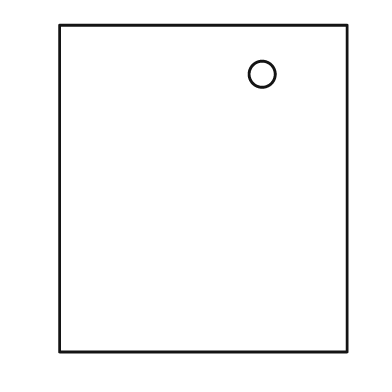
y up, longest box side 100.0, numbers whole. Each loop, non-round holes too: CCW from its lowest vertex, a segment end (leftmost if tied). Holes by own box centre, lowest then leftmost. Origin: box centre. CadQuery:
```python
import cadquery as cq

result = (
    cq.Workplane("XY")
    .moveTo(-44.0, -50.0)
    .lineTo(44.0, -50.0)
    .lineTo(44.0, 50.0)
    .lineTo(-44.0, 50.0)
    .close()
    .moveTo(18.0, 35.0)
    .circle(4.0)
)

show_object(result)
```